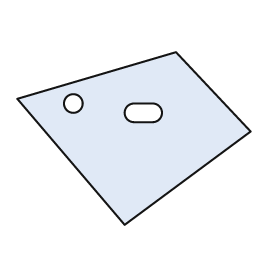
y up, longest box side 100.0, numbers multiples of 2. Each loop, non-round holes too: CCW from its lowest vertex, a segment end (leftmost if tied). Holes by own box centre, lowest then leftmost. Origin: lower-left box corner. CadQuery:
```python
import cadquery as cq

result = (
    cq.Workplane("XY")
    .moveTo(46.0, 0.0)
    .lineTo(100.0, 40.0)
    .lineTo(68.0, 74.0)
    .lineTo(0.0, 54.0)
    .close()
    .moveTo(50.0, 44.0)
    .lineTo(58.0, 44.0)
    .threePointArc((62.0, 48.0), (58.0, 52.0))
    .lineTo(50.0, 52.0)
    .threePointArc((46.0, 48.0), (50.0, 44.0))
    .close()
    .moveTo(24.0, 52.0)
    .circle(4.0)
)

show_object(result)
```